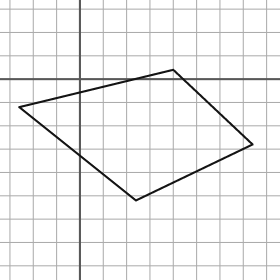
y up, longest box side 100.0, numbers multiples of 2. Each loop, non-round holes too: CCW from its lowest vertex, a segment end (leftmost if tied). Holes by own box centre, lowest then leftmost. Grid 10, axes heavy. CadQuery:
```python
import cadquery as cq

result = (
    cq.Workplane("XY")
    .moveTo(24.0, -52.0)
    .lineTo(74.0, -28.0)
    .lineTo(40.0, 4.0)
    .lineTo(-26.0, -12.0)
    .close()
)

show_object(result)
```